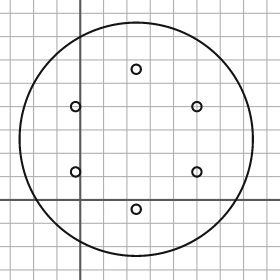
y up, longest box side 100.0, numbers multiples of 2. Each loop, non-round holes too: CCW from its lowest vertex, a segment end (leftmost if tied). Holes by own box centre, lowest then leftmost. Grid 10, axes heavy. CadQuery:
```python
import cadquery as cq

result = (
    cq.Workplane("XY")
    .moveTo(24.0, 26.0)
    .circle(50.0)
    .moveTo(24.0, -4.0)
    .circle(2.0)
    .moveTo(-2.0, 12.0)
    .circle(2.0)
    .moveTo(50.0, 12.0)
    .circle(2.0)
    .moveTo(-2.0, 40.0)
    .circle(2.0)
    .moveTo(50.0, 40.0)
    .circle(2.0)
    .moveTo(24.0, 56.0)
    .circle(2.0)
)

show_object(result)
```